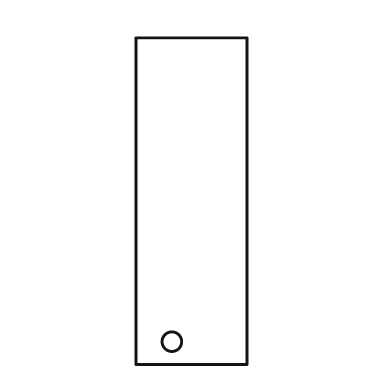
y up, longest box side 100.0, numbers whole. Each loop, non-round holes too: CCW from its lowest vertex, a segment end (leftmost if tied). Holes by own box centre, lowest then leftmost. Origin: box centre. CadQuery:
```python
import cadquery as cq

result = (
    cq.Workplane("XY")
    .moveTo(-17.0, -50.0)
    .lineTo(17.0, -50.0)
    .lineTo(17.0, 50.0)
    .lineTo(-17.0, 50.0)
    .close()
    .moveTo(-6.0, -43.0)
    .circle(3.0)
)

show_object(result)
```